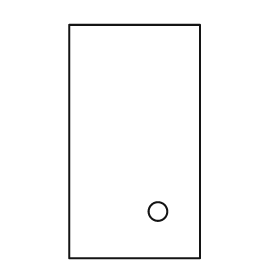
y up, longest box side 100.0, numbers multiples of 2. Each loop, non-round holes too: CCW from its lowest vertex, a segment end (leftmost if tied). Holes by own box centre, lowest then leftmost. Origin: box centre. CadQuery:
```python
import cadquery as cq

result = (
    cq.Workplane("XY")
    .moveTo(-28.0, -50.0)
    .lineTo(28.0, -50.0)
    .lineTo(28.0, 50.0)
    .lineTo(-28.0, 50.0)
    .close()
    .moveTo(10.0, -30.0)
    .circle(4.0)
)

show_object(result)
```